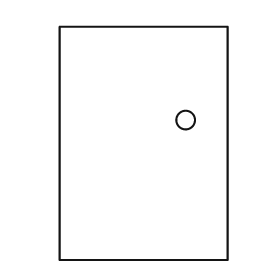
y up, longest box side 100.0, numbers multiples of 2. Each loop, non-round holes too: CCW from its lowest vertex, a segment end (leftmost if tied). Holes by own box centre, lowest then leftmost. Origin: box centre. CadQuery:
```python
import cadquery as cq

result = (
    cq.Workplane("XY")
    .moveTo(-36.0, -50.0)
    .lineTo(36.0, -50.0)
    .lineTo(36.0, 50.0)
    .lineTo(-36.0, 50.0)
    .close()
    .moveTo(18.0, 10.0)
    .circle(4.0)
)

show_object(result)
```